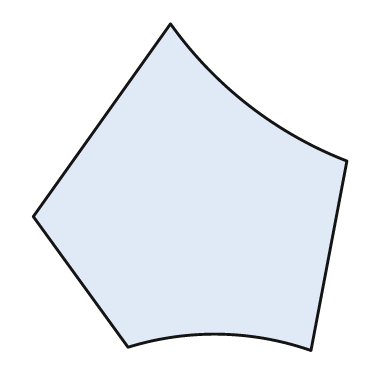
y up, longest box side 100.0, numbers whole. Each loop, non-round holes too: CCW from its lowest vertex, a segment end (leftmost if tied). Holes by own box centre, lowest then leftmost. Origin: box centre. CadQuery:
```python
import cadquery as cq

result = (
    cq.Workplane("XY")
    .moveTo(37.0, -50.0)
    .lineTo(48.0, 8.0)
    .threePointArc((18.0, 25.0), (-6.0, 50.0))
    .lineTo(-48.0, -9.0)
    .lineTo(-19.0, -49.0)
    .threePointArc((9.0, -45.0), (37.0, -50.0))
    .close()
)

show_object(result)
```